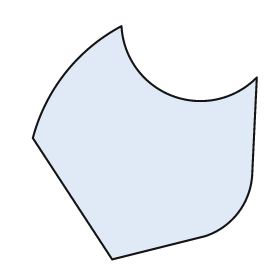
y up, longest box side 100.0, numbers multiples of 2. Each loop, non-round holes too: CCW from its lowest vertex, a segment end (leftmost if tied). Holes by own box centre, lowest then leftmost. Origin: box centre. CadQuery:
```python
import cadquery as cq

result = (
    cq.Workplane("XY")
    .moveTo(-14.0, -50.0)
    .lineTo(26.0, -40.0)
    .threePointArc((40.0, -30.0), (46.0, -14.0))
    .lineTo(48.0, 28.0)
    .threePointArc((12.0, 20.0), (-10.0, 50.0))
    .threePointArc((-34.0, 30.0), (-48.0, 2.0))
    .close()
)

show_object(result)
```